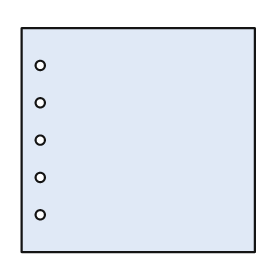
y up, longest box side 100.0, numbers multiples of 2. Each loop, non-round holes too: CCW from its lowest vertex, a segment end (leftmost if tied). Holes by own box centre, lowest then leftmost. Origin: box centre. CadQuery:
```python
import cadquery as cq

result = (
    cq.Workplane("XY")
    .moveTo(-50.0, -48.0)
    .lineTo(50.0, -48.0)
    .lineTo(50.0, 48.0)
    .lineTo(-50.0, 48.0)
    .close()
    .moveTo(-42.0, -32.0)
    .circle(2.0)
    .moveTo(-42.0, -16.0)
    .circle(2.0)
    .moveTo(-42.0, 0.0)
    .circle(2.0)
    .moveTo(-42.0, 16.0)
    .circle(2.0)
    .moveTo(-42.0, 32.0)
    .circle(2.0)
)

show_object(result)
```